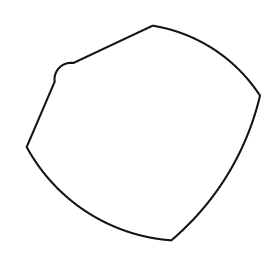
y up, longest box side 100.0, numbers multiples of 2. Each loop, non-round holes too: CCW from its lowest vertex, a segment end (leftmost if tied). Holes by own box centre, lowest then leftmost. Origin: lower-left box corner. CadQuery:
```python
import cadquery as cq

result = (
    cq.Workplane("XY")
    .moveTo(62.0, 0.0)
    .threePointArc((86.0, 28.0), (100.0, 62.0))
    .threePointArc((80.0, 82.0), (54.0, 92.0))
    .lineTo(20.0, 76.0)
    .threePointArc((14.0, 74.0), (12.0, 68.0))
    .lineTo(0.0, 40.0)
    .threePointArc((26.0, 12.0), (62.0, 0.0))
    .close()
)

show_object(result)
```